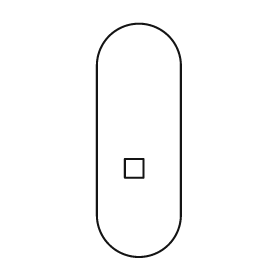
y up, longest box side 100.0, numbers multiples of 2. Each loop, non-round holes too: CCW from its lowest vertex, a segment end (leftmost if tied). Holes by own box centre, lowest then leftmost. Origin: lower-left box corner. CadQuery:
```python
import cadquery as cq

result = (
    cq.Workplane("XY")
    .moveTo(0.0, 18.0)
    .threePointArc((18.0, 0.0), (36.0, 18.0))
    .lineTo(36.0, 82.0)
    .threePointArc((18.0, 100.0), (0.0, 82.0))
    .close()
    .moveTo(12.0, 34.0)
    .lineTo(20.0, 34.0)
    .lineTo(20.0, 42.0)
    .lineTo(12.0, 42.0)
    .close()
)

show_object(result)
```